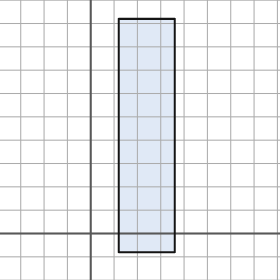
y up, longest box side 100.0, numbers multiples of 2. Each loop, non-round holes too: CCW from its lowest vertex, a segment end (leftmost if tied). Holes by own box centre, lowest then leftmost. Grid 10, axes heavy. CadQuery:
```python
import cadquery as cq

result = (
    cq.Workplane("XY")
    .moveTo(12.0, -8.0)
    .lineTo(36.0, -8.0)
    .lineTo(36.0, 92.0)
    .lineTo(12.0, 92.0)
    .close()
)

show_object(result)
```